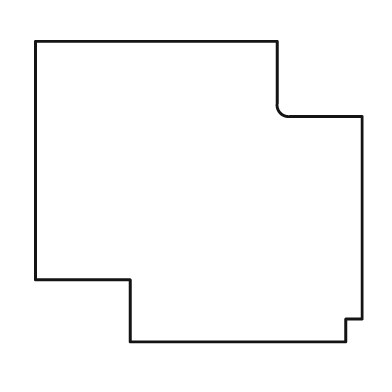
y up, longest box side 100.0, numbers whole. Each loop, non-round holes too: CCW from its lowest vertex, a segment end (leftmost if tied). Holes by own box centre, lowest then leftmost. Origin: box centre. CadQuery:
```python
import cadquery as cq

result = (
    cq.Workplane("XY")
    .moveTo(-21.0, -46.0)
    .lineTo(45.0, -46.0)
    .lineTo(45.0, -39.0)
    .lineTo(50.0, -39.0)
    .lineTo(50.0, 23.0)
    .lineTo(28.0, 23.0)
    .threePointArc((25.0, 24.0), (24.0, 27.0))
    .lineTo(24.0, 46.0)
    .lineTo(-50.0, 46.0)
    .lineTo(-50.0, -27.0)
    .lineTo(-21.0, -27.0)
    .close()
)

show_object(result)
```